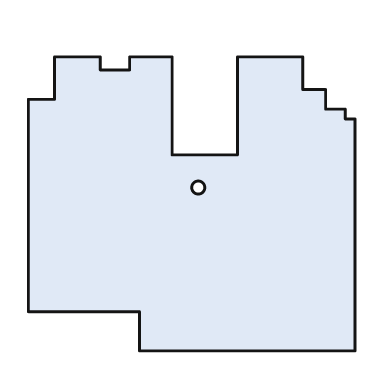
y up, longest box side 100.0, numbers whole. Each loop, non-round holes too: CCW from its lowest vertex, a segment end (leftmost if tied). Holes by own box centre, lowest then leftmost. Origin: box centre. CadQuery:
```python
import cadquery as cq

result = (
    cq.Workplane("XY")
    .moveTo(-16.0, -45.0)
    .lineTo(50.0, -45.0)
    .lineTo(50.0, 26.0)
    .lineTo(47.0, 26.0)
    .lineTo(47.0, 29.0)
    .lineTo(41.0, 29.0)
    .lineTo(41.0, 35.0)
    .lineTo(34.0, 35.0)
    .lineTo(34.0, 45.0)
    .lineTo(14.0, 45.0)
    .lineTo(14.0, 15.0)
    .lineTo(-6.0, 15.0)
    .lineTo(-6.0, 45.0)
    .lineTo(-19.0, 45.0)
    .lineTo(-19.0, 41.0)
    .lineTo(-28.0, 41.0)
    .lineTo(-28.0, 45.0)
    .lineTo(-42.0, 45.0)
    .lineTo(-42.0, 32.0)
    .lineTo(-50.0, 32.0)
    .lineTo(-50.0, -33.0)
    .lineTo(-16.0, -33.0)
    .close()
    .moveTo(2.0, 5.0)
    .circle(2.0)
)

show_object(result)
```